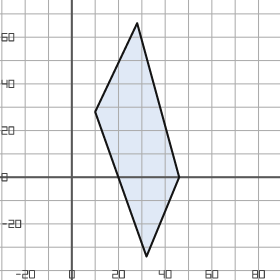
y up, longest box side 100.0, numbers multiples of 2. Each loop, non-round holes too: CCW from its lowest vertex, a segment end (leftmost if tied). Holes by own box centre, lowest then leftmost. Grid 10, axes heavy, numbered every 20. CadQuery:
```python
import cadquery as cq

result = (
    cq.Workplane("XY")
    .moveTo(32.0, -34.0)
    .lineTo(46.0, 0.0)
    .lineTo(28.0, 66.0)
    .lineTo(10.0, 28.0)
    .close()
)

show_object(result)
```